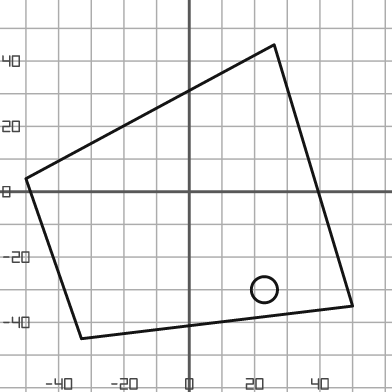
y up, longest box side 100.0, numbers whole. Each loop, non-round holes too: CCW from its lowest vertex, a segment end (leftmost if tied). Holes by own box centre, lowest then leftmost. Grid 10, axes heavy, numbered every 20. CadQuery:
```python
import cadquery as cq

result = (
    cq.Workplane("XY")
    .moveTo(-33.0, -45.0)
    .lineTo(50.0, -35.0)
    .lineTo(26.0, 45.0)
    .lineTo(-50.0, 4.0)
    .close()
    .moveTo(23.0, -30.0)
    .circle(4.0)
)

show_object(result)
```